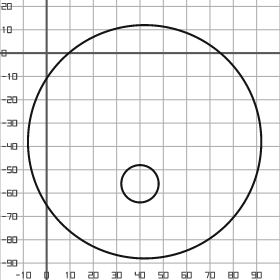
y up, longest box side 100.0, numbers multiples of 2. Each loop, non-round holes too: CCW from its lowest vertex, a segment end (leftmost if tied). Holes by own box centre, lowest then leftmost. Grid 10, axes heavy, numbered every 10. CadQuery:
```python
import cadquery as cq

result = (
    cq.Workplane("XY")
    .moveTo(42.0, -38.0)
    .circle(50.0)
    .moveTo(40.0, -56.0)
    .circle(8.0)
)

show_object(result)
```